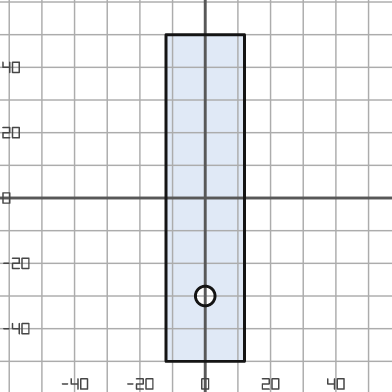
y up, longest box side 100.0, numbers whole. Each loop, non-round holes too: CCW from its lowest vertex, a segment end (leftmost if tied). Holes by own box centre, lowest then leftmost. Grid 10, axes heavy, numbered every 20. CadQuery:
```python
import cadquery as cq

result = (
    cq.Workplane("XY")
    .moveTo(-12.0, -50.0)
    .lineTo(12.0, -50.0)
    .lineTo(12.0, 50.0)
    .lineTo(-12.0, 50.0)
    .close()
    .moveTo(0.0, -30.0)
    .circle(3.0)
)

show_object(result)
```